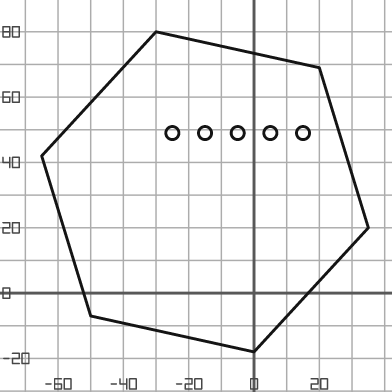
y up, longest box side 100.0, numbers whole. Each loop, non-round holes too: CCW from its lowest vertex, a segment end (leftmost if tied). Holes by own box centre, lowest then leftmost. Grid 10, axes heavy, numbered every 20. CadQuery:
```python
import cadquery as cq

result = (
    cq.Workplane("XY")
    .moveTo(0.0, -18.0)
    .lineTo(35.0, 20.0)
    .lineTo(20.0, 69.0)
    .lineTo(-30.0, 80.0)
    .lineTo(-65.0, 42.0)
    .lineTo(-50.0, -7.0)
    .close()
    .moveTo(-25.0, 49.0)
    .circle(2.0)
    .moveTo(-15.0, 49.0)
    .circle(2.0)
    .moveTo(-5.0, 49.0)
    .circle(2.0)
    .moveTo(5.0, 49.0)
    .circle(2.0)
    .moveTo(15.0, 49.0)
    .circle(2.0)
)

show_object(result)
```